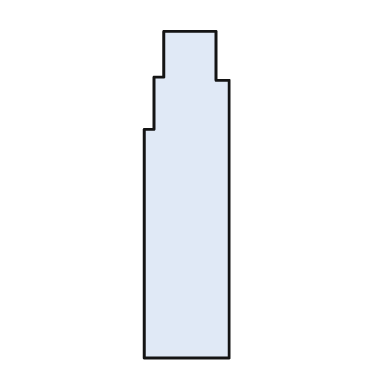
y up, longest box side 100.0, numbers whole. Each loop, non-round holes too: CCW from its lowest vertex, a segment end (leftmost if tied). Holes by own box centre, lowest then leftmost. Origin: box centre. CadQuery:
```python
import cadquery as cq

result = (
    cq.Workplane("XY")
    .moveTo(-13.0, -50.0)
    .lineTo(13.0, -50.0)
    .lineTo(13.0, 35.0)
    .lineTo(9.0, 35.0)
    .lineTo(9.0, 50.0)
    .lineTo(-7.0, 50.0)
    .lineTo(-7.0, 36.0)
    .lineTo(-10.0, 36.0)
    .lineTo(-10.0, 20.0)
    .lineTo(-13.0, 20.0)
    .close()
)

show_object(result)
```